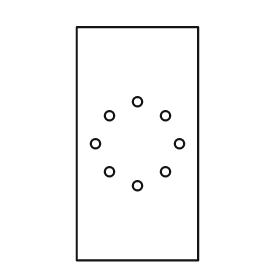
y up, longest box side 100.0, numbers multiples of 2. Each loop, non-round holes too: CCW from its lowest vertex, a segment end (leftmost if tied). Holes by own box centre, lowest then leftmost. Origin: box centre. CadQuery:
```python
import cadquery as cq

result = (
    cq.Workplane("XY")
    .moveTo(-26.0, -50.0)
    .lineTo(26.0, -50.0)
    .lineTo(26.0, 50.0)
    .lineTo(-26.0, 50.0)
    .close()
    .moveTo(0.0, -18.0)
    .circle(2.0)
    .moveTo(-12.0, -12.0)
    .circle(2.0)
    .moveTo(12.0, -12.0)
    .circle(2.0)
    .moveTo(-18.0, 0.0)
    .circle(2.0)
    .moveTo(18.0, 0.0)
    .circle(2.0)
    .moveTo(-12.0, 12.0)
    .circle(2.0)
    .moveTo(12.0, 12.0)
    .circle(2.0)
    .moveTo(0.0, 18.0)
    .circle(2.0)
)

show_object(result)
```